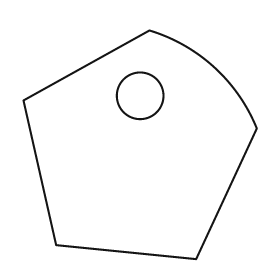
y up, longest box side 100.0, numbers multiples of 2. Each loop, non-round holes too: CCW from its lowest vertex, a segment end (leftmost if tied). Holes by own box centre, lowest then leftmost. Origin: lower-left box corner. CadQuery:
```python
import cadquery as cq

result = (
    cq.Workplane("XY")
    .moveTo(74.0, 0.0)
    .lineTo(100.0, 56.0)
    .threePointArc((82.0, 82.0), (54.0, 98.0))
    .lineTo(0.0, 68.0)
    .lineTo(14.0, 6.0)
    .close()
    .moveTo(50.0, 70.0)
    .circle(10.0)
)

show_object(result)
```